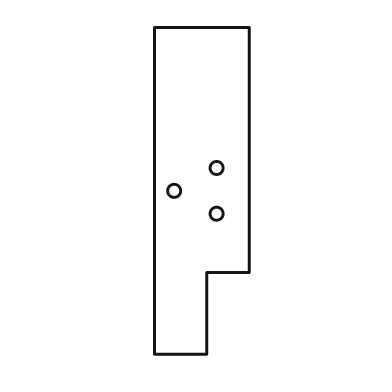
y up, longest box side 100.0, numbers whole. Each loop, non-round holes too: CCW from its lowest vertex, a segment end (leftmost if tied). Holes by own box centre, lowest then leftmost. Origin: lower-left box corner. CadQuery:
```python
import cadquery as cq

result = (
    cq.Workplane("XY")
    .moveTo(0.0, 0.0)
    .lineTo(16.0, 0.0)
    .lineTo(16.0, 25.0)
    .lineTo(29.0, 25.0)
    .lineTo(29.0, 100.0)
    .lineTo(0.0, 100.0)
    .close()
    .moveTo(19.0, 43.0)
    .circle(2.0)
    .moveTo(6.0, 50.0)
    .circle(2.0)
    .moveTo(19.0, 57.0)
    .circle(2.0)
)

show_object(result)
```